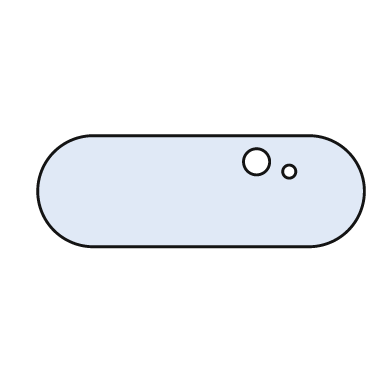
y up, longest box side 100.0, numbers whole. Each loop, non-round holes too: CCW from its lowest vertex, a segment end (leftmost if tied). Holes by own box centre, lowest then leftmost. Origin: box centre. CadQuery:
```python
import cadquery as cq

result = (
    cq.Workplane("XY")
    .moveTo(-33.0, -17.0)
    .lineTo(33.0, -17.0)
    .threePointArc((50.0, 0.0), (33.0, 17.0))
    .lineTo(-33.0, 17.0)
    .threePointArc((-50.0, 0.0), (-33.0, -17.0))
    .close()
    .moveTo(27.0, 6.0)
    .circle(2.0)
    .moveTo(17.0, 9.0)
    .circle(4.0)
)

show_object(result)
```